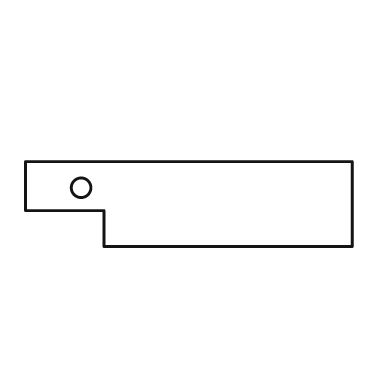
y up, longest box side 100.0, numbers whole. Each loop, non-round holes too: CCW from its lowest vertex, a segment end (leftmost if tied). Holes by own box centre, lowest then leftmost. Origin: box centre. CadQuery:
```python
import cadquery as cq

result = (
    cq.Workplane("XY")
    .moveTo(-26.0, -13.0)
    .lineTo(50.0, -13.0)
    .lineTo(50.0, 13.0)
    .lineTo(-50.0, 13.0)
    .lineTo(-50.0, -2.0)
    .lineTo(-26.0, -2.0)
    .close()
    .moveTo(-33.0, 5.0)
    .circle(3.0)
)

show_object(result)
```